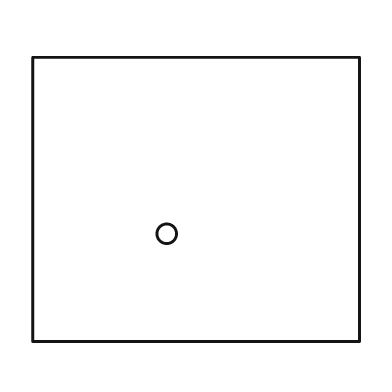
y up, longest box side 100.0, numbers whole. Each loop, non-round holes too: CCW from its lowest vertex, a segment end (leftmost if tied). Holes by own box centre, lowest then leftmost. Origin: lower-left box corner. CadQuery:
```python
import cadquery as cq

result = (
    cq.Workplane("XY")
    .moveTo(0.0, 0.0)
    .lineTo(100.0, 0.0)
    .lineTo(100.0, 87.0)
    .lineTo(0.0, 87.0)
    .close()
    .moveTo(41.0, 33.0)
    .circle(3.0)
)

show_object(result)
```